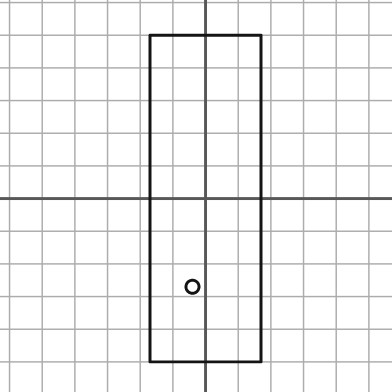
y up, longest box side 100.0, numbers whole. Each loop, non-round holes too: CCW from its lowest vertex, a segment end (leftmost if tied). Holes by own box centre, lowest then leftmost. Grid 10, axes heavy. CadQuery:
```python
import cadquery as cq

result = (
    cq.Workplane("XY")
    .moveTo(-17.0, -50.0)
    .lineTo(17.0, -50.0)
    .lineTo(17.0, 50.0)
    .lineTo(-17.0, 50.0)
    .close()
    .moveTo(-4.0, -27.0)
    .circle(2.0)
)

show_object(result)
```